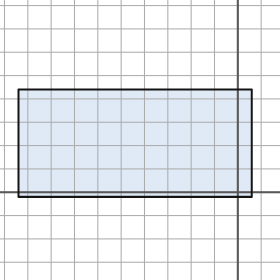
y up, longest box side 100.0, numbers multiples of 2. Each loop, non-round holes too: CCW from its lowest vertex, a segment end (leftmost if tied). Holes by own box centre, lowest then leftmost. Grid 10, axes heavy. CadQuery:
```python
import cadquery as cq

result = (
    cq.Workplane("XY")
    .moveTo(-94.0, -2.0)
    .lineTo(6.0, -2.0)
    .lineTo(6.0, 44.0)
    .lineTo(-94.0, 44.0)
    .close()
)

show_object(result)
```